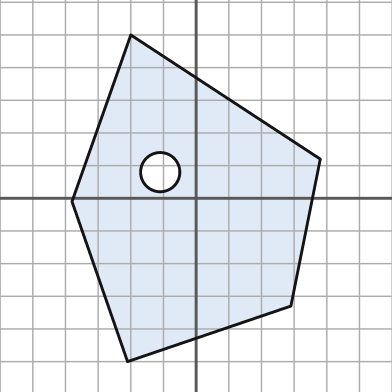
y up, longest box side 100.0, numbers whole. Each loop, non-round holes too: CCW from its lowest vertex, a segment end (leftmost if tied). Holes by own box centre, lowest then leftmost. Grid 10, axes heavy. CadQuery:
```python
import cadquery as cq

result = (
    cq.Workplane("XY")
    .moveTo(-21.0, -50.0)
    .lineTo(29.0, -33.0)
    .lineTo(38.0, 12.0)
    .lineTo(-20.0, 50.0)
    .lineTo(-38.0, -1.0)
    .close()
    .moveTo(-11.0, 8.0)
    .circle(6.0)
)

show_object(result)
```